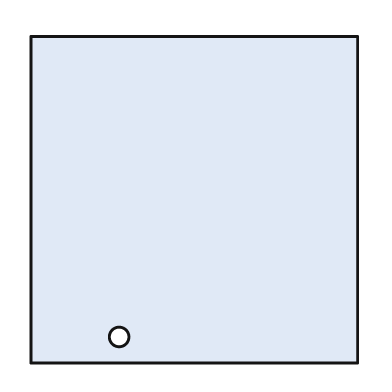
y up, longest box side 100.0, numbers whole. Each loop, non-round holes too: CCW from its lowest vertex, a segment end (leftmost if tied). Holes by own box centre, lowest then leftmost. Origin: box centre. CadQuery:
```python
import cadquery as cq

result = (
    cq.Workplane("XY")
    .moveTo(-50.0, -50.0)
    .lineTo(50.0, -50.0)
    .lineTo(50.0, 50.0)
    .lineTo(-50.0, 50.0)
    .close()
    .moveTo(-23.0, -42.0)
    .circle(3.0)
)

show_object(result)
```